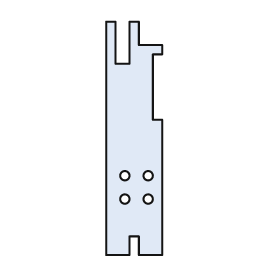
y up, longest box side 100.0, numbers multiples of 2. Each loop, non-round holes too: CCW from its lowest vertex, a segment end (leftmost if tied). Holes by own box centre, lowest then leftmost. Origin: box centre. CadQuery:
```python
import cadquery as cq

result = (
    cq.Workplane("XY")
    .moveTo(-12.0, -50.0)
    .lineTo(-2.0, -50.0)
    .lineTo(-2.0, -42.0)
    .lineTo(2.0, -42.0)
    .lineTo(2.0, -50.0)
    .lineTo(12.0, -50.0)
    .lineTo(12.0, 8.0)
    .lineTo(8.0, 8.0)
    .lineTo(8.0, 36.0)
    .lineTo(12.0, 36.0)
    .lineTo(12.0, 40.0)
    .lineTo(2.0, 40.0)
    .lineTo(2.0, 50.0)
    .lineTo(-2.0, 50.0)
    .lineTo(-2.0, 32.0)
    .lineTo(-8.0, 32.0)
    .lineTo(-8.0, 50.0)
    .lineTo(-12.0, 50.0)
    .close()
    .moveTo(-4.0, -26.0)
    .circle(2.0)
    .moveTo(6.0, -26.0)
    .circle(2.0)
    .moveTo(-4.0, -16.0)
    .circle(2.0)
    .moveTo(6.0, -16.0)
    .circle(2.0)
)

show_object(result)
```